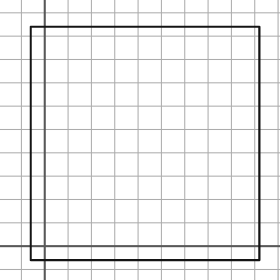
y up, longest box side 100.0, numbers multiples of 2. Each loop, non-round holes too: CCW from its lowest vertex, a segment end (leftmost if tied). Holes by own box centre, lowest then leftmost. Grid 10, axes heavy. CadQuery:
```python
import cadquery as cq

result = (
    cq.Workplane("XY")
    .moveTo(-6.0, -6.0)
    .lineTo(92.0, -6.0)
    .lineTo(92.0, 94.0)
    .lineTo(-6.0, 94.0)
    .close()
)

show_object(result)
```